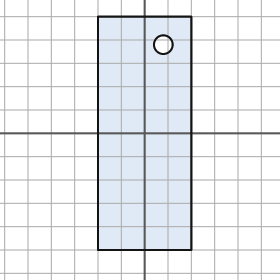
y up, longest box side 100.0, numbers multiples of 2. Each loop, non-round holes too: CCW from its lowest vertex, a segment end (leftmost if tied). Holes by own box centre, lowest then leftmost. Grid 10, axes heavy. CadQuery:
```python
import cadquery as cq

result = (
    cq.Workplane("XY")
    .moveTo(-20.0, -50.0)
    .lineTo(20.0, -50.0)
    .lineTo(20.0, 50.0)
    .lineTo(-20.0, 50.0)
    .close()
    .moveTo(8.0, 38.0)
    .circle(4.0)
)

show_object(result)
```